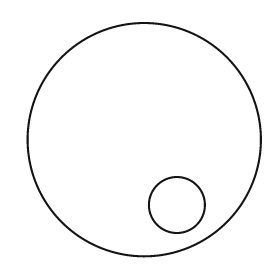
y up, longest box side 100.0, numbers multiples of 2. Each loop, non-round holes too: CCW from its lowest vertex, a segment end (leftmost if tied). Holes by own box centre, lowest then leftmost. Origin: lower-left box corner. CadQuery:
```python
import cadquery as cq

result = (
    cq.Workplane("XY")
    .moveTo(50.0, 50.0)
    .circle(50.0)
    .moveTo(64.0, 22.0)
    .circle(12.0)
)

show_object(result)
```